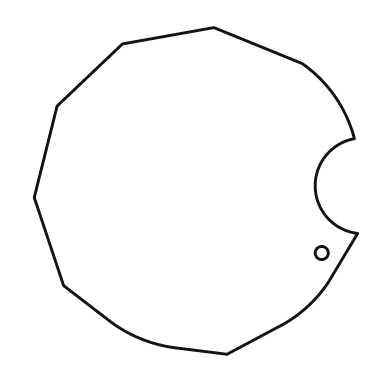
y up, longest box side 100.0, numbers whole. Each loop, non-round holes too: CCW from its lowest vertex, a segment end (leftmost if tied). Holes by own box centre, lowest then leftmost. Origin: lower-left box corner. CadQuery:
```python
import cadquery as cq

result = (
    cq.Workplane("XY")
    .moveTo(59.0, 0.0)
    .lineTo(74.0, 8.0)
    .threePointArc((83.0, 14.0), (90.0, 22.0))
    .lineTo(99.0, 37.0)
    .threePointArc((86.0, 51.0), (98.0, 66.0))
    .threePointArc((92.0, 79.0), (82.0, 89.0))
    .lineTo(55.0, 100.0)
    .lineTo(27.0, 95.0)
    .lineTo(7.0, 76.0)
    .lineTo(0.0, 48.0)
    .lineTo(9.0, 21.0)
    .lineTo(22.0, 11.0)
    .threePointArc((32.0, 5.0), (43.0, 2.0))
    .close()
    .moveTo(88.0, 31.0)
    .circle(2.0)
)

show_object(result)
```